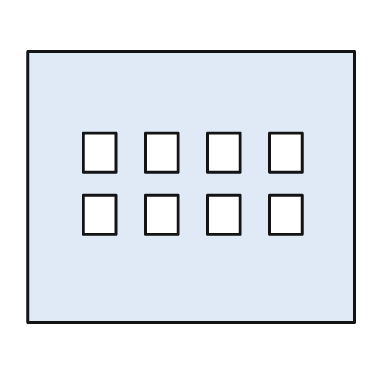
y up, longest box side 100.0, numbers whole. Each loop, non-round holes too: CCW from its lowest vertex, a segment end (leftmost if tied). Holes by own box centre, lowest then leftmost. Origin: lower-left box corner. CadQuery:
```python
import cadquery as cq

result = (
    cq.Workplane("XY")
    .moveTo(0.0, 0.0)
    .lineTo(100.0, 0.0)
    .lineTo(100.0, 83.0)
    .lineTo(0.0, 83.0)
    .close()
    .moveTo(17.0, 27.0)
    .lineTo(27.0, 27.0)
    .lineTo(27.0, 39.0)
    .lineTo(17.0, 39.0)
    .close()
    .moveTo(36.0, 27.0)
    .lineTo(46.0, 27.0)
    .lineTo(46.0, 39.0)
    .lineTo(36.0, 39.0)
    .close()
    .moveTo(55.0, 27.0)
    .lineTo(65.0, 27.0)
    .lineTo(65.0, 39.0)
    .lineTo(55.0, 39.0)
    .close()
    .moveTo(74.0, 27.0)
    .lineTo(84.0, 27.0)
    .lineTo(84.0, 39.0)
    .lineTo(74.0, 39.0)
    .close()
    .moveTo(17.0, 46.0)
    .lineTo(27.0, 46.0)
    .lineTo(27.0, 58.0)
    .lineTo(17.0, 58.0)
    .close()
    .moveTo(36.0, 46.0)
    .lineTo(46.0, 46.0)
    .lineTo(46.0, 58.0)
    .lineTo(36.0, 58.0)
    .close()
    .moveTo(55.0, 46.0)
    .lineTo(65.0, 46.0)
    .lineTo(65.0, 58.0)
    .lineTo(55.0, 58.0)
    .close()
    .moveTo(74.0, 46.0)
    .lineTo(84.0, 46.0)
    .lineTo(84.0, 58.0)
    .lineTo(74.0, 58.0)
    .close()
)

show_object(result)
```